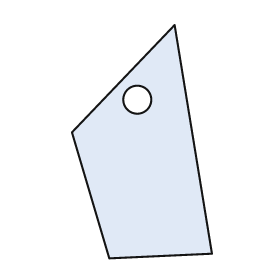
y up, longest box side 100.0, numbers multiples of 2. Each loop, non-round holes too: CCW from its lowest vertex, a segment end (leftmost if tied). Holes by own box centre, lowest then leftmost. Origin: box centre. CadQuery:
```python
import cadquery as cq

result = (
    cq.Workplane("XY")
    .moveTo(-14.0, -50.0)
    .lineTo(30.0, -48.0)
    .lineTo(14.0, 50.0)
    .lineTo(-30.0, 4.0)
    .close()
    .moveTo(-2.0, 18.0)
    .circle(6.0)
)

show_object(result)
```